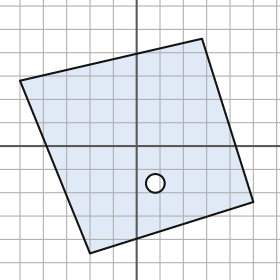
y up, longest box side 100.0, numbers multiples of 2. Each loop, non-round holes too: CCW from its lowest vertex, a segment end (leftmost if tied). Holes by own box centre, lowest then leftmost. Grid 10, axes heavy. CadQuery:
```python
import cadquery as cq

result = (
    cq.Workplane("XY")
    .moveTo(-20.0, -46.0)
    .lineTo(50.0, -24.0)
    .lineTo(28.0, 46.0)
    .lineTo(-50.0, 28.0)
    .close()
    .moveTo(8.0, -16.0)
    .circle(4.0)
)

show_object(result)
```